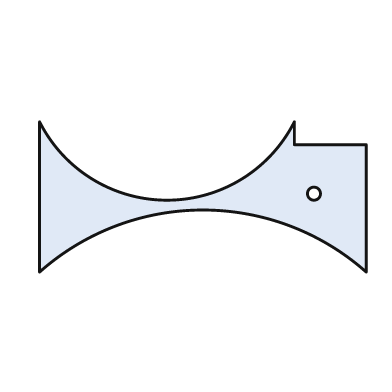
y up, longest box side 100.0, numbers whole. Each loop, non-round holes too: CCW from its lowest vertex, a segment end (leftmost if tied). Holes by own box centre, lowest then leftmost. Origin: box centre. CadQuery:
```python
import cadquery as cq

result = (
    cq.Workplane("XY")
    .moveTo(-50.0, -23.0)
    .threePointArc((0.0, -4.0), (50.0, -23.0))
    .lineTo(50.0, 16.0)
    .lineTo(28.0, 16.0)
    .lineTo(28.0, 23.0)
    .threePointArc((-11.0, -1.0), (-50.0, 23.0))
    .close()
    .moveTo(34.0, 1.0)
    .circle(2.0)
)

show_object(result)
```